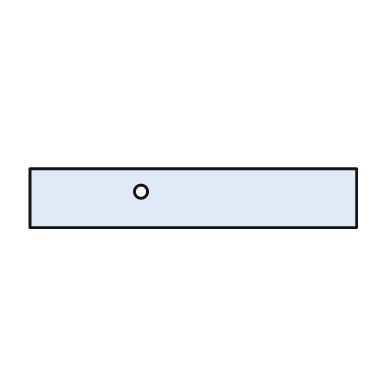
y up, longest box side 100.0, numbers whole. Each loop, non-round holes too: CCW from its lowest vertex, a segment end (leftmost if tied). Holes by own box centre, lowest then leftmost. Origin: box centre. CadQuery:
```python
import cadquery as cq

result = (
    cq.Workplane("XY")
    .moveTo(-50.0, -9.0)
    .lineTo(50.0, -9.0)
    .lineTo(50.0, 9.0)
    .lineTo(-50.0, 9.0)
    .close()
    .moveTo(-16.0, 2.0)
    .circle(2.0)
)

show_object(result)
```